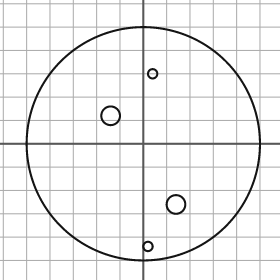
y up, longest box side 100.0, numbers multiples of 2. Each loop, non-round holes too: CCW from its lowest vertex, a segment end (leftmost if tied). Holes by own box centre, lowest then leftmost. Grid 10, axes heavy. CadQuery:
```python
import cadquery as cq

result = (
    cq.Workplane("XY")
    .moveTo(0.0, 0.0)
    .circle(50.0)
    .moveTo(2.0, -44.0)
    .circle(2.0)
    .moveTo(14.0, -26.0)
    .circle(4.0)
    .moveTo(-14.0, 12.0)
    .circle(4.0)
    .moveTo(4.0, 30.0)
    .circle(2.0)
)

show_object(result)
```